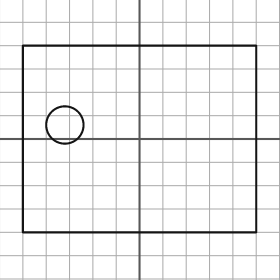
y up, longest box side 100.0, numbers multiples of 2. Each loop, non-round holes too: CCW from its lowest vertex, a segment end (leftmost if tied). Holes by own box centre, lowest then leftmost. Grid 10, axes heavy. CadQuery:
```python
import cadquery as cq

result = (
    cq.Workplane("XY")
    .moveTo(-50.0, -40.0)
    .lineTo(50.0, -40.0)
    .lineTo(50.0, 40.0)
    .lineTo(-50.0, 40.0)
    .close()
    .moveTo(-32.0, 6.0)
    .circle(8.0)
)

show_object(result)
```